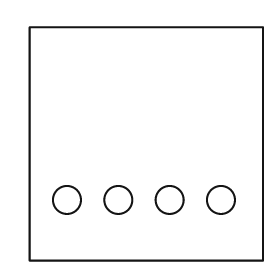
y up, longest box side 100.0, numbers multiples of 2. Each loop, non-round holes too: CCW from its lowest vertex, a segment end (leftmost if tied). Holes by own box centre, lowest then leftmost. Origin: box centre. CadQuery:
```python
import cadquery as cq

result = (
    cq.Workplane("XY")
    .moveTo(-50.0, -50.0)
    .lineTo(50.0, -50.0)
    .lineTo(50.0, 50.0)
    .lineTo(-50.0, 50.0)
    .close()
    .moveTo(-34.0, -24.0)
    .circle(6.0)
    .moveTo(-12.0, -24.0)
    .circle(6.0)
    .moveTo(10.0, -24.0)
    .circle(6.0)
    .moveTo(32.0, -24.0)
    .circle(6.0)
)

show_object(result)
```